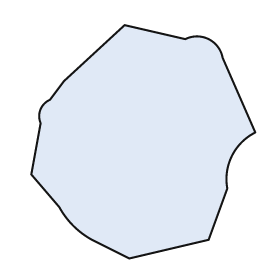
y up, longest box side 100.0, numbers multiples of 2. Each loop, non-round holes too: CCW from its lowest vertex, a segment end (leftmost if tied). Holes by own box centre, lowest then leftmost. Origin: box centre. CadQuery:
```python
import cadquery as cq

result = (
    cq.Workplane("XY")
    .moveTo(-6.0, -50.0)
    .lineTo(28.0, -42.0)
    .lineTo(36.0, -20.0)
    .threePointArc((38.0, -6.0), (48.0, 4.0))
    .lineTo(34.0, 36.0)
    .threePointArc((28.0, 44.0), (18.0, 44.0))
    .lineTo(-8.0, 50.0)
    .lineTo(-34.0, 26.0)
    .lineTo(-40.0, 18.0)
    .threePointArc((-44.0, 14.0), (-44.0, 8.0))
    .lineTo(-48.0, -14.0)
    .lineTo(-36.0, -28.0)
    .threePointArc((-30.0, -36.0), (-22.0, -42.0))
    .close()
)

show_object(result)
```